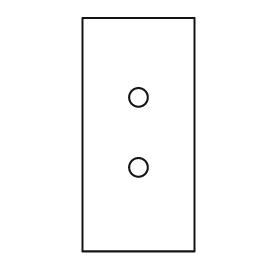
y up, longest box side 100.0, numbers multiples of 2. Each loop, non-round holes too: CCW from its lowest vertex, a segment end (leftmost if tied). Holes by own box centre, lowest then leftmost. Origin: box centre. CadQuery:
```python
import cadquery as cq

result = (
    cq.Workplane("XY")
    .moveTo(-24.0, -50.0)
    .lineTo(24.0, -50.0)
    .lineTo(24.0, 50.0)
    .lineTo(-24.0, 50.0)
    .close()
    .moveTo(0.0, -14.0)
    .circle(4.0)
    .moveTo(0.0, 16.0)
    .circle(4.0)
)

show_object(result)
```